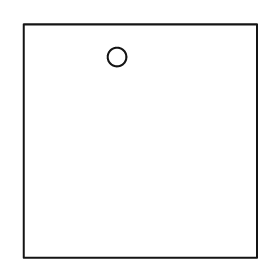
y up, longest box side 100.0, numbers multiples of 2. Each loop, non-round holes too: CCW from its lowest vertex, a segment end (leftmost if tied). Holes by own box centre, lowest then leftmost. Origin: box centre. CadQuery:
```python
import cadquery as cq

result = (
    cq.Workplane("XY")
    .moveTo(-50.0, -50.0)
    .lineTo(50.0, -50.0)
    .lineTo(50.0, 50.0)
    .lineTo(-50.0, 50.0)
    .close()
    .moveTo(-10.0, 36.0)
    .circle(4.0)
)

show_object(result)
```